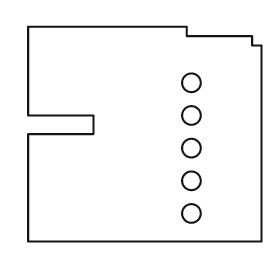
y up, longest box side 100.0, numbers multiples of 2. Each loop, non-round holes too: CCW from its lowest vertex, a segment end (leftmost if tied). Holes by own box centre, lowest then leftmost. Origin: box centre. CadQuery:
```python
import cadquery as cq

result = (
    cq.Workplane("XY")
    .moveTo(-50.0, -46.0)
    .lineTo(50.0, -46.0)
    .lineTo(50.0, 38.0)
    .lineTo(46.0, 38.0)
    .lineTo(46.0, 42.0)
    .lineTo(18.0, 42.0)
    .lineTo(18.0, 46.0)
    .lineTo(-50.0, 46.0)
    .lineTo(-50.0, 8.0)
    .lineTo(-22.0, 8.0)
    .lineTo(-22.0, 0.0)
    .lineTo(-50.0, 0.0)
    .close()
    .moveTo(20.0, -34.0)
    .circle(4.0)
    .moveTo(20.0, -20.0)
    .circle(4.0)
    .moveTo(20.0, -6.0)
    .circle(4.0)
    .moveTo(20.0, 8.0)
    .circle(4.0)
    .moveTo(20.0, 22.0)
    .circle(4.0)
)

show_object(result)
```